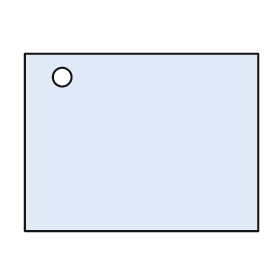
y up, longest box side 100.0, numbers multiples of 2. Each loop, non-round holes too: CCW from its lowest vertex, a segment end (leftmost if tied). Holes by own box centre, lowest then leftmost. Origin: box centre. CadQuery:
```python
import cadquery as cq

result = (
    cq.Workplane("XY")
    .moveTo(-50.0, -38.0)
    .lineTo(50.0, -38.0)
    .lineTo(50.0, 38.0)
    .lineTo(-50.0, 38.0)
    .close()
    .moveTo(-34.0, 28.0)
    .circle(4.0)
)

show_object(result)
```